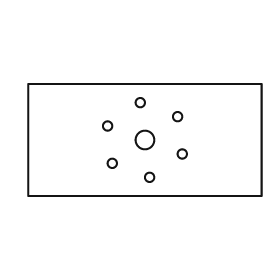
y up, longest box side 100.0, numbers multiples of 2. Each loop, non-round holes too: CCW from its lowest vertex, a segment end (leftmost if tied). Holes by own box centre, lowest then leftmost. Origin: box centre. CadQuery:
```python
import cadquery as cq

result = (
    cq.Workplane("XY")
    .moveTo(-50.0, -24.0)
    .lineTo(50.0, -24.0)
    .lineTo(50.0, 24.0)
    .lineTo(-50.0, 24.0)
    .close()
    .moveTo(2.0, -16.0)
    .circle(2.0)
    .moveTo(-14.0, -10.0)
    .circle(2.0)
    .moveTo(16.0, -6.0)
    .circle(2.0)
    .moveTo(0.0, 0.0)
    .circle(4.0)
    .moveTo(-16.0, 6.0)
    .circle(2.0)
    .moveTo(14.0, 10.0)
    .circle(2.0)
    .moveTo(-2.0, 16.0)
    .circle(2.0)
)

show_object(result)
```